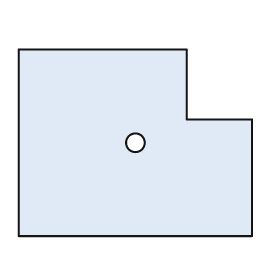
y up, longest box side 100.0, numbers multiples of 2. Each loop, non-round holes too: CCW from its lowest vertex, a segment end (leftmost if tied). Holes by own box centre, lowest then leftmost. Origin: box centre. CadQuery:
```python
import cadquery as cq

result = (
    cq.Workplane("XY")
    .moveTo(-50.0, -40.0)
    .lineTo(50.0, -40.0)
    .lineTo(50.0, 10.0)
    .lineTo(22.0, 10.0)
    .lineTo(22.0, 40.0)
    .lineTo(-50.0, 40.0)
    .close()
    .moveTo(0.0, 0.0)
    .circle(4.0)
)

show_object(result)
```